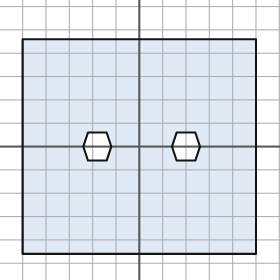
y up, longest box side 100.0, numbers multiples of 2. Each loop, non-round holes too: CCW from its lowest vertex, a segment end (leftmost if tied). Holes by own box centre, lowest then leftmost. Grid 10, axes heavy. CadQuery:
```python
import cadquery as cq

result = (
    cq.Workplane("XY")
    .moveTo(-50.0, -46.0)
    .lineTo(50.0, -46.0)
    .lineTo(50.0, 46.0)
    .lineTo(-50.0, 46.0)
    .close()
    .moveTo(-22.0, -6.0)
    .lineTo(-14.0, -6.0)
    .lineTo(-12.0, 0.0)
    .lineTo(-14.0, 6.0)
    .lineTo(-22.0, 6.0)
    .lineTo(-24.0, 0.0)
    .close()
    .moveTo(16.0, -6.0)
    .lineTo(24.0, -6.0)
    .lineTo(26.0, 0.0)
    .lineTo(24.0, 6.0)
    .lineTo(16.0, 6.0)
    .lineTo(14.0, 0.0)
    .close()
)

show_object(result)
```